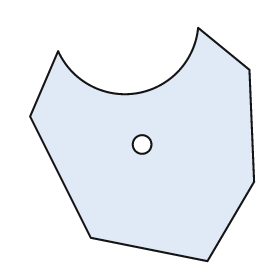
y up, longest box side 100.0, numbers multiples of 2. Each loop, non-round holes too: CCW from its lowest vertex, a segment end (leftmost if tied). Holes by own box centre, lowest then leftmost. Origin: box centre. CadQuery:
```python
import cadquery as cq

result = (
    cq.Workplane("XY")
    .moveTo(28.0, -50.0)
    .lineTo(48.0, -16.0)
    .lineTo(46.0, 32.0)
    .lineTo(24.0, 50.0)
    .threePointArc((-2.0, 22.0), (-36.0, 40.0))
    .lineTo(-48.0, 12.0)
    .lineTo(-22.0, -40.0)
    .close()
    .moveTo(0.0, 0.0)
    .circle(4.0)
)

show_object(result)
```